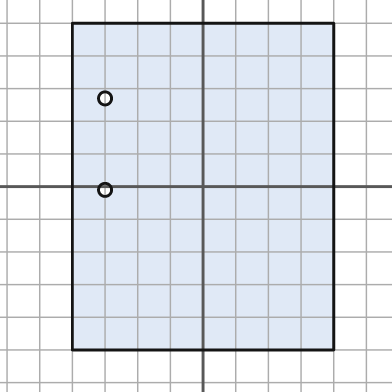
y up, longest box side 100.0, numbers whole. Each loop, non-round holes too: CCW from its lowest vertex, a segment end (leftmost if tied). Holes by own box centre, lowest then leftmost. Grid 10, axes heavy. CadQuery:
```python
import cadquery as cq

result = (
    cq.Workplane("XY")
    .moveTo(-40.0, -50.0)
    .lineTo(40.0, -50.0)
    .lineTo(40.0, 50.0)
    .lineTo(-40.0, 50.0)
    .close()
    .moveTo(-30.0, -1.0)
    .circle(2.0)
    .moveTo(-30.0, 27.0)
    .circle(2.0)
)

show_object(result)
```